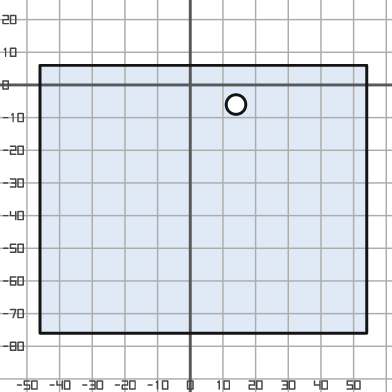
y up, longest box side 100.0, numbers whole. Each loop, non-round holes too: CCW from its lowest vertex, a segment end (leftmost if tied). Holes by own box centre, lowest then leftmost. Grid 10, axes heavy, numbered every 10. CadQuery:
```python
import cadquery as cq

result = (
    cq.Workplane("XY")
    .moveTo(-46.0, -76.0)
    .lineTo(54.0, -76.0)
    .lineTo(54.0, 6.0)
    .lineTo(-46.0, 6.0)
    .close()
    .moveTo(14.0, -6.0)
    .circle(3.0)
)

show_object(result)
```